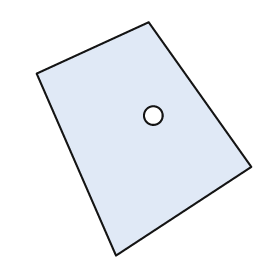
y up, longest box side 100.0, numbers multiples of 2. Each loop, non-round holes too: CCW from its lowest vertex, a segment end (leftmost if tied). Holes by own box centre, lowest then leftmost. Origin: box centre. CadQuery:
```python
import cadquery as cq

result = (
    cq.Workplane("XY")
    .moveTo(-12.0, -50.0)
    .lineTo(46.0, -12.0)
    .lineTo(2.0, 50.0)
    .lineTo(-46.0, 28.0)
    .close()
    .moveTo(4.0, 10.0)
    .circle(4.0)
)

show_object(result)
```